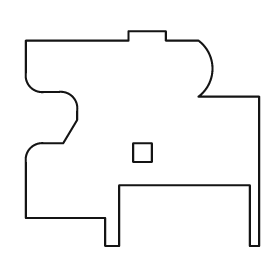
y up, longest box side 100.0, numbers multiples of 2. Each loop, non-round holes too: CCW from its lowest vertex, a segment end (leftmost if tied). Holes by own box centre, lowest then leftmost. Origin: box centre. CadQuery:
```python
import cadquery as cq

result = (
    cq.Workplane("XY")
    .moveTo(-16.0, -46.0)
    .lineTo(-10.0, -46.0)
    .lineTo(-10.0, -20.0)
    .lineTo(46.0, -20.0)
    .lineTo(46.0, -46.0)
    .lineTo(50.0, -46.0)
    .lineTo(50.0, 18.0)
    .lineTo(24.0, 18.0)
    .threePointArc((30.0, 30.0), (24.0, 42.0))
    .lineTo(10.0, 42.0)
    .lineTo(10.0, 46.0)
    .lineTo(-6.0, 46.0)
    .lineTo(-6.0, 42.0)
    .lineTo(-50.0, 42.0)
    .lineTo(-50.0, 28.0)
    .threePointArc((-48.0, 22.0), (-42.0, 20.0))
    .lineTo(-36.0, 20.0)
    .threePointArc((-30.0, 18.0), (-28.0, 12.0))
    .lineTo(-28.0, 8.0)
    .lineTo(-34.0, -2.0)
    .lineTo(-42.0, -2.0)
    .threePointArc((-48.0, -4.0), (-50.0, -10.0))
    .lineTo(-50.0, -34.0)
    .lineTo(-16.0, -34.0)
    .close()
    .moveTo(-4.0, -10.0)
    .lineTo(4.0, -10.0)
    .lineTo(4.0, -2.0)
    .lineTo(-4.0, -2.0)
    .close()
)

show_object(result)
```